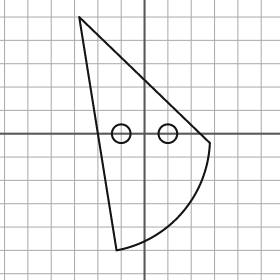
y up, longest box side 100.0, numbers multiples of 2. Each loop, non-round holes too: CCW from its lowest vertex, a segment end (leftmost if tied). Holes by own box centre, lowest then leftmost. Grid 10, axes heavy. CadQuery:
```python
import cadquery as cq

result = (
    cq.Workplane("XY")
    .moveTo(-12.0, -50.0)
    .threePointArc((16.0, -34.0), (28.0, -4.0))
    .lineTo(-28.0, 50.0)
    .close()
    .moveTo(-10.0, 0.0)
    .circle(4.0)
    .moveTo(10.0, 0.0)
    .circle(4.0)
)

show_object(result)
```